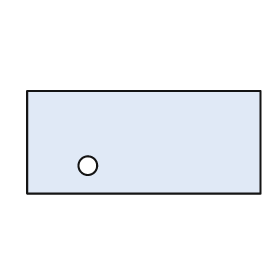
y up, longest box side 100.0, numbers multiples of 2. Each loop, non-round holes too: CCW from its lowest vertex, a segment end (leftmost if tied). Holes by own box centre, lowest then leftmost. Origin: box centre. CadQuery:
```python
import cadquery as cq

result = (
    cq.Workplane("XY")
    .moveTo(-50.0, -22.0)
    .lineTo(50.0, -22.0)
    .lineTo(50.0, 22.0)
    .lineTo(-50.0, 22.0)
    .close()
    .moveTo(-24.0, -10.0)
    .circle(4.0)
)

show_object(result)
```